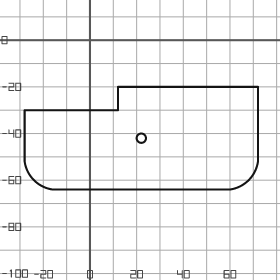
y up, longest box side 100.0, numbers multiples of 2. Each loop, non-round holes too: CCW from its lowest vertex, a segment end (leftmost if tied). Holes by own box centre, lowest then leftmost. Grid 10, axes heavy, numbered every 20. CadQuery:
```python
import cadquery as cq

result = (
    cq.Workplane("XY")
    .moveTo(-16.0, -64.0)
    .lineTo(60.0, -64.0)
    .threePointArc((68.0, -60.0), (72.0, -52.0))
    .lineTo(72.0, -20.0)
    .lineTo(12.0, -20.0)
    .lineTo(12.0, -30.0)
    .lineTo(-28.0, -30.0)
    .lineTo(-28.0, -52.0)
    .threePointArc((-24.0, -60.0), (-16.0, -64.0))
    .close()
    .moveTo(22.0, -42.0)
    .circle(2.0)
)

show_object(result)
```